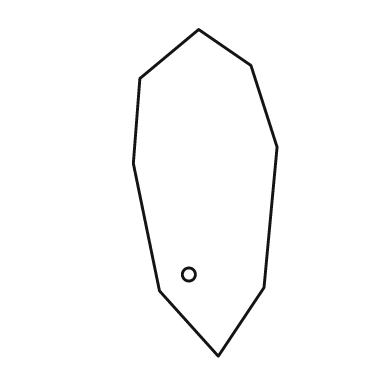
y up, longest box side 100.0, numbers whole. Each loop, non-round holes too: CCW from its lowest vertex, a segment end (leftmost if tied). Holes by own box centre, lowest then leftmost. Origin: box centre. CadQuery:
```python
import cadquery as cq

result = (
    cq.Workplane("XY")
    .moveTo(4.0, -50.0)
    .lineTo(18.0, -29.0)
    .lineTo(22.0, 14.0)
    .lineTo(14.0, 39.0)
    .lineTo(-2.0, 50.0)
    .lineTo(-20.0, 35.0)
    .lineTo(-22.0, 9.0)
    .lineTo(-14.0, -30.0)
    .close()
    .moveTo(-5.0, -25.0)
    .circle(2.0)
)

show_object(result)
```